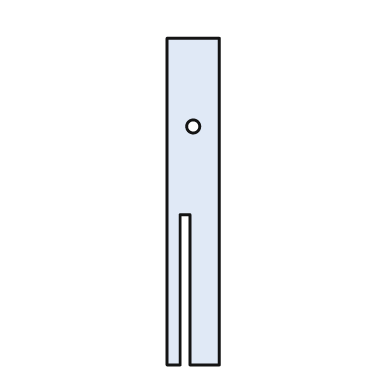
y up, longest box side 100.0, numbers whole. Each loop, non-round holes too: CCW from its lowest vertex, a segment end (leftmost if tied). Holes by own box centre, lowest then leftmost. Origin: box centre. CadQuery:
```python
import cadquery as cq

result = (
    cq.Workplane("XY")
    .moveTo(-8.0, -50.0)
    .lineTo(-4.0, -50.0)
    .lineTo(-4.0, -4.0)
    .lineTo(-1.0, -4.0)
    .lineTo(-1.0, -50.0)
    .lineTo(8.0, -50.0)
    .lineTo(8.0, 50.0)
    .lineTo(-8.0, 50.0)
    .close()
    .moveTo(0.0, 23.0)
    .circle(2.0)
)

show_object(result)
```